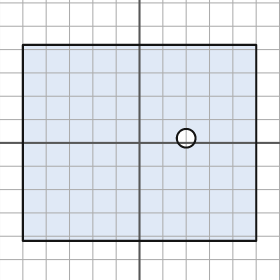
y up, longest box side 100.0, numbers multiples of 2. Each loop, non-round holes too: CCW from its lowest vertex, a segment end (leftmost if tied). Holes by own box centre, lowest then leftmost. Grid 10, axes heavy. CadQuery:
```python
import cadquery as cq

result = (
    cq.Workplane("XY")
    .moveTo(-50.0, -42.0)
    .lineTo(50.0, -42.0)
    .lineTo(50.0, 42.0)
    .lineTo(-50.0, 42.0)
    .close()
    .moveTo(20.0, 2.0)
    .circle(4.0)
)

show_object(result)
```